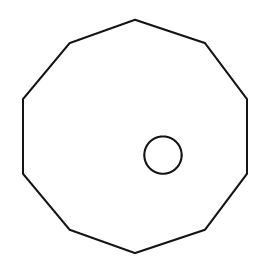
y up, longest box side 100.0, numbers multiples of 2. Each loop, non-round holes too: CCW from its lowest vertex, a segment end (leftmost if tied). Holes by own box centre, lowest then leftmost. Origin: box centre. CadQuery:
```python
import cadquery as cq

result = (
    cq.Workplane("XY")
    .moveTo(0.0, -50.0)
    .lineTo(30.0, -40.0)
    .lineTo(48.0, -16.0)
    .lineTo(48.0, 16.0)
    .lineTo(30.0, 40.0)
    .lineTo(0.0, 50.0)
    .lineTo(-28.0, 40.0)
    .lineTo(-48.0, 16.0)
    .lineTo(-48.0, -16.0)
    .lineTo(-28.0, -40.0)
    .close()
    .moveTo(12.0, -8.0)
    .circle(8.0)
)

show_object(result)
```